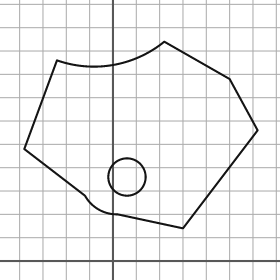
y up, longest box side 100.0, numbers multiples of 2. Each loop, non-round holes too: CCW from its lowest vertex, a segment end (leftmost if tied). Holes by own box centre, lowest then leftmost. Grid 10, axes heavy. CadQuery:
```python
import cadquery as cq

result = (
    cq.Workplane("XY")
    .moveTo(30.0, 14.0)
    .lineTo(62.0, 56.0)
    .lineTo(50.0, 78.0)
    .lineTo(22.0, 94.0)
    .threePointArc((0.0, 84.0), (-24.0, 86.0))
    .lineTo(-38.0, 48.0)
    .lineTo(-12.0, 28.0)
    .threePointArc((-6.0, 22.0), (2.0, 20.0))
    .close()
    .moveTo(6.0, 36.0)
    .circle(8.0)
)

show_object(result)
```